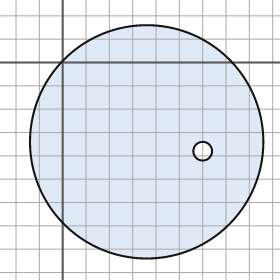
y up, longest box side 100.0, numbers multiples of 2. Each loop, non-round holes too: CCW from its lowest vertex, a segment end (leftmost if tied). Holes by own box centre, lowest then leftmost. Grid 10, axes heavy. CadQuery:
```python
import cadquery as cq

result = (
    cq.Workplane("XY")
    .moveTo(36.0, -34.0)
    .circle(50.0)
    .moveTo(60.0, -38.0)
    .circle(4.0)
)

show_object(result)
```